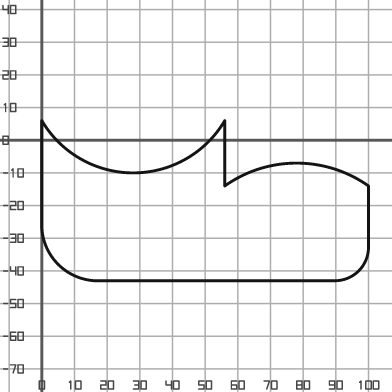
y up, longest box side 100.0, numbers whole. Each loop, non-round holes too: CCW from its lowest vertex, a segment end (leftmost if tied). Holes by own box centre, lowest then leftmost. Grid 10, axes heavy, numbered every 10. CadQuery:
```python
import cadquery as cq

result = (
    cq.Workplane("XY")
    .moveTo(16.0, -43.0)
    .lineTo(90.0, -43.0)
    .threePointArc((97.0, -40.0), (100.0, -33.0))
    .lineTo(100.0, -14.0)
    .threePointArc((78.0, -7.0), (56.0, -14.0))
    .lineTo(56.0, 6.0)
    .threePointArc((28.0, -10.0), (0.0, 6.0))
    .lineTo(0.0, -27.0)
    .threePointArc((5.0, -38.0), (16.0, -43.0))
    .close()
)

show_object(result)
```